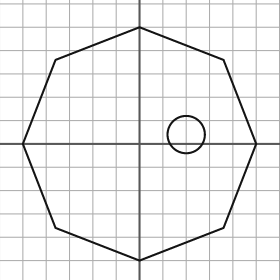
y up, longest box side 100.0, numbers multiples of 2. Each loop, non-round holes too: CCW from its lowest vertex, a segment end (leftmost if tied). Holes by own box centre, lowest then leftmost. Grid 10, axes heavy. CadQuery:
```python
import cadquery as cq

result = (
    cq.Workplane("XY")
    .moveTo(0.0, -50.0)
    .lineTo(36.0, -36.0)
    .lineTo(50.0, 0.0)
    .lineTo(36.0, 36.0)
    .lineTo(0.0, 50.0)
    .lineTo(-36.0, 36.0)
    .lineTo(-50.0, 0.0)
    .lineTo(-36.0, -36.0)
    .close()
    .moveTo(20.0, 4.0)
    .circle(8.0)
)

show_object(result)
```